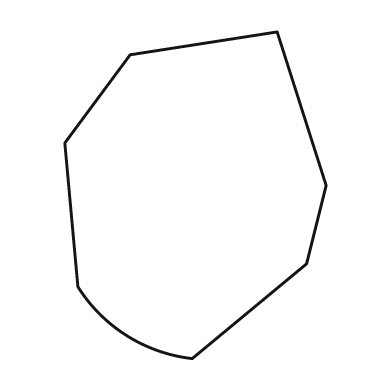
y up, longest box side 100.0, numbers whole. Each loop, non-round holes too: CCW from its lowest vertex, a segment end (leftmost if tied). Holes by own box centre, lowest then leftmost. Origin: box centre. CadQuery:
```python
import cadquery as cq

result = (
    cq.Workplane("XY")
    .moveTo(-1.0, -50.0)
    .lineTo(34.0, -21.0)
    .lineTo(40.0, 3.0)
    .lineTo(25.0, 50.0)
    .lineTo(-20.0, 43.0)
    .lineTo(-40.0, 16.0)
    .lineTo(-36.0, -28.0)
    .threePointArc((-21.0, -43.0), (-1.0, -50.0))
    .close()
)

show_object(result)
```